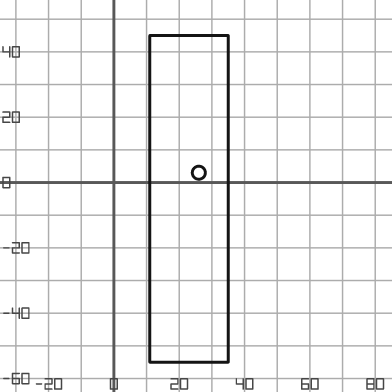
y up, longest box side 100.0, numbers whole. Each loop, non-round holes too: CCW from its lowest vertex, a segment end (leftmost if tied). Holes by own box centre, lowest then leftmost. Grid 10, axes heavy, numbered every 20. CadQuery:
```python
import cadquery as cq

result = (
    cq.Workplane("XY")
    .moveTo(11.0, -55.0)
    .lineTo(35.0, -55.0)
    .lineTo(35.0, 45.0)
    .lineTo(11.0, 45.0)
    .close()
    .moveTo(26.0, 3.0)
    .circle(2.0)
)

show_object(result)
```